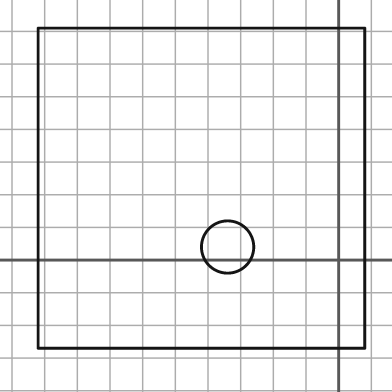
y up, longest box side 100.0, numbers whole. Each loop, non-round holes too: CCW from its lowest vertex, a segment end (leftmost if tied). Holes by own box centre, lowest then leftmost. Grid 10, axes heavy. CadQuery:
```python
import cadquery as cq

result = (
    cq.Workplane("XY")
    .moveTo(-92.0, -27.0)
    .lineTo(8.0, -27.0)
    .lineTo(8.0, 71.0)
    .lineTo(-92.0, 71.0)
    .close()
    .moveTo(-34.0, 4.0)
    .circle(8.0)
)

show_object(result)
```